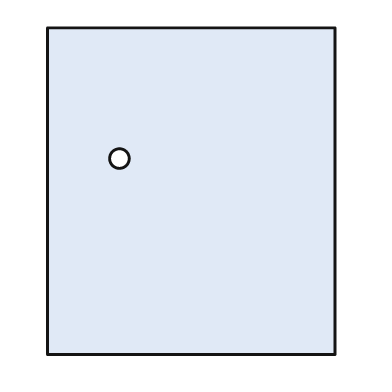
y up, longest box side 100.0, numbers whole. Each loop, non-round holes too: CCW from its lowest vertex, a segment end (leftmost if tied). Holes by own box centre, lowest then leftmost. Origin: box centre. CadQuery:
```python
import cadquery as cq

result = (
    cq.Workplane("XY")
    .moveTo(-44.0, -50.0)
    .lineTo(44.0, -50.0)
    .lineTo(44.0, 50.0)
    .lineTo(-44.0, 50.0)
    .close()
    .moveTo(-22.0, 10.0)
    .circle(3.0)
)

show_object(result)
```